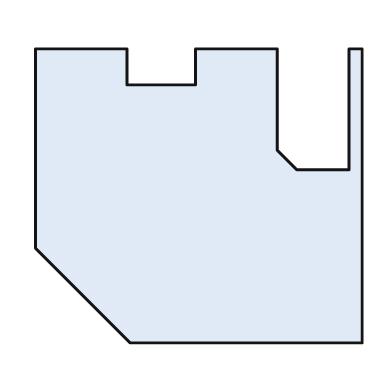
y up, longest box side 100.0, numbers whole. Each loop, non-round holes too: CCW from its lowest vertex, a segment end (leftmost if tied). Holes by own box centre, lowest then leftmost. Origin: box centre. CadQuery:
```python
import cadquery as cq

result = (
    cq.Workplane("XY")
    .moveTo(-21.0, -45.0)
    .lineTo(50.0, -45.0)
    .lineTo(50.0, 45.0)
    .lineTo(46.0, 45.0)
    .lineTo(46.0, 8.0)
    .lineTo(30.0, 8.0)
    .lineTo(24.0, 14.0)
    .lineTo(24.0, 45.0)
    .lineTo(-1.0, 45.0)
    .lineTo(-1.0, 34.0)
    .lineTo(-22.0, 34.0)
    .lineTo(-22.0, 45.0)
    .lineTo(-50.0, 45.0)
    .lineTo(-50.0, -16.0)
    .close()
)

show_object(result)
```